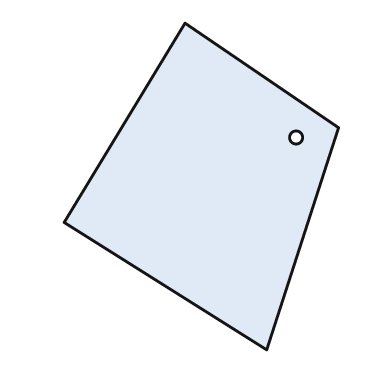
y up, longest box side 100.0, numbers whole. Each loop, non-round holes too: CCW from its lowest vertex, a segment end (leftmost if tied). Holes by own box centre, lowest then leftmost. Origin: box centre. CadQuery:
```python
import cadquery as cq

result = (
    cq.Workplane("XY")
    .moveTo(20.0, -50.0)
    .lineTo(42.0, 18.0)
    .lineTo(-5.0, 50.0)
    .lineTo(-42.0, -11.0)
    .close()
    .moveTo(29.0, 15.0)
    .circle(2.0)
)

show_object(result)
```